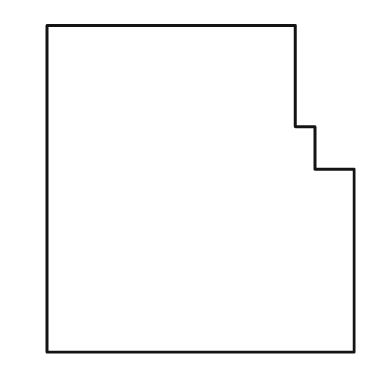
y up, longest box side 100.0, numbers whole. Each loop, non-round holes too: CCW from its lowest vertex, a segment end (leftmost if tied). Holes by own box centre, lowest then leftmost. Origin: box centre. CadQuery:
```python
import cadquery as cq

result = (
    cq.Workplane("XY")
    .moveTo(-47.0, -50.0)
    .lineTo(47.0, -50.0)
    .lineTo(47.0, 6.0)
    .lineTo(35.0, 6.0)
    .lineTo(35.0, 19.0)
    .lineTo(29.0, 19.0)
    .lineTo(29.0, 50.0)
    .lineTo(-47.0, 50.0)
    .close()
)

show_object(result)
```